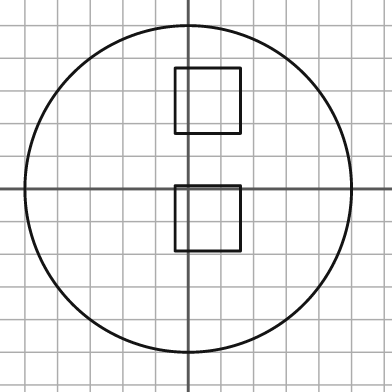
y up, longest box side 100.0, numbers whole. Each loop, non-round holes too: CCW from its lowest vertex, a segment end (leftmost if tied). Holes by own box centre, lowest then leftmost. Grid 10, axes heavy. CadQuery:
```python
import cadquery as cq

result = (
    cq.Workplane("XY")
    .moveTo(0.0, 0.0)
    .circle(50.0)
    .moveTo(-4.0, -19.0)
    .lineTo(16.0, -19.0)
    .lineTo(16.0, 1.0)
    .lineTo(-4.0, 1.0)
    .close()
    .moveTo(-4.0, 17.0)
    .lineTo(16.0, 17.0)
    .lineTo(16.0, 37.0)
    .lineTo(-4.0, 37.0)
    .close()
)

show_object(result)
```